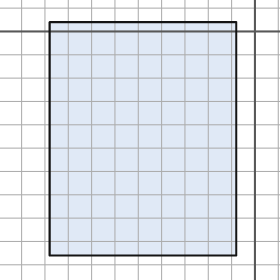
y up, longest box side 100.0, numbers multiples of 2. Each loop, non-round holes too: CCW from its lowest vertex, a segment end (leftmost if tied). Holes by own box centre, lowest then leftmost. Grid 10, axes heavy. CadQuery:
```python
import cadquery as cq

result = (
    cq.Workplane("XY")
    .moveTo(-88.0, -96.0)
    .lineTo(-8.0, -96.0)
    .lineTo(-8.0, 4.0)
    .lineTo(-88.0, 4.0)
    .close()
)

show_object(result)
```